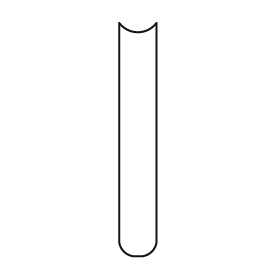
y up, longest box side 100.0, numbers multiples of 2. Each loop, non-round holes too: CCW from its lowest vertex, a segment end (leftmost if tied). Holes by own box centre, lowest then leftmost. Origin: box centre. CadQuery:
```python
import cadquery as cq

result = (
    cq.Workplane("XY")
    .moveTo(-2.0, -50.0)
    .lineTo(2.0, -50.0)
    .threePointArc((6.0, -48.0), (8.0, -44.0))
    .lineTo(8.0, 50.0)
    .threePointArc((0.0, 46.0), (-8.0, 50.0))
    .lineTo(-8.0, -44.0)
    .threePointArc((-6.0, -48.0), (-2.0, -50.0))
    .close()
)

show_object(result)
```